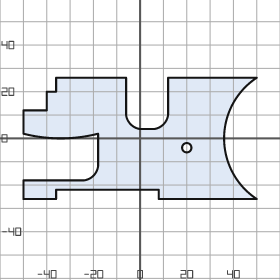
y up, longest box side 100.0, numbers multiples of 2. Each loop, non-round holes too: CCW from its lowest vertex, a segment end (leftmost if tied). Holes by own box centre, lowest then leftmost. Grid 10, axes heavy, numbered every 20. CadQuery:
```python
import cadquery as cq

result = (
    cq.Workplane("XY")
    .moveTo(-50.0, -26.0)
    .lineTo(-36.0, -26.0)
    .lineTo(-36.0, -22.0)
    .lineTo(8.0, -22.0)
    .lineTo(8.0, -26.0)
    .lineTo(50.0, -26.0)
    .threePointArc((36.0, 0.0), (50.0, 26.0))
    .lineTo(12.0, 26.0)
    .lineTo(12.0, 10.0)
    .threePointArc((10.0, 6.0), (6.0, 4.0))
    .lineTo(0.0, 4.0)
    .threePointArc((-4.0, 6.0), (-6.0, 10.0))
    .lineTo(-6.0, 26.0)
    .lineTo(-36.0, 26.0)
    .lineTo(-36.0, 20.0)
    .lineTo(-40.0, 20.0)
    .lineTo(-40.0, 12.0)
    .lineTo(-50.0, 12.0)
    .lineTo(-50.0, 2.0)
    .threePointArc((-34.0, 0.0), (-18.0, 2.0))
    .lineTo(-18.0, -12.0)
    .threePointArc((-20.0, -16.0), (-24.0, -18.0))
    .lineTo(-50.0, -18.0)
    .close()
    .moveTo(20.0, -4.0)
    .circle(2.0)
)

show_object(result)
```